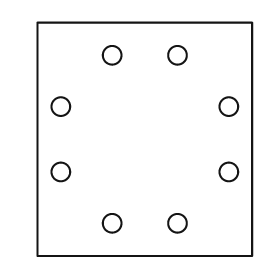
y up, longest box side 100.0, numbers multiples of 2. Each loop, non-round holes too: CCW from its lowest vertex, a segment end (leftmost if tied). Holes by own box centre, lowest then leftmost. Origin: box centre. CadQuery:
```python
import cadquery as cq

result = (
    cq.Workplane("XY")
    .moveTo(-46.0, -50.0)
    .lineTo(46.0, -50.0)
    .lineTo(46.0, 50.0)
    .lineTo(-46.0, 50.0)
    .close()
    .moveTo(-14.0, -36.0)
    .circle(4.0)
    .moveTo(14.0, -36.0)
    .circle(4.0)
    .moveTo(-36.0, -14.0)
    .circle(4.0)
    .moveTo(36.0, -14.0)
    .circle(4.0)
    .moveTo(-36.0, 14.0)
    .circle(4.0)
    .moveTo(36.0, 14.0)
    .circle(4.0)
    .moveTo(-14.0, 36.0)
    .circle(4.0)
    .moveTo(14.0, 36.0)
    .circle(4.0)
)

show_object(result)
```